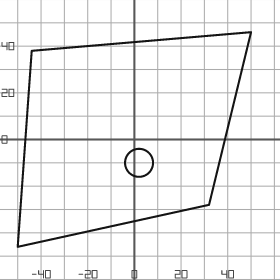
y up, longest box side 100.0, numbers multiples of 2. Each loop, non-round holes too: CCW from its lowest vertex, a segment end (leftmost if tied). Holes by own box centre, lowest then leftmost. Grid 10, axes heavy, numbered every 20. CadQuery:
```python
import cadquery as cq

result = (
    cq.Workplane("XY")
    .moveTo(-50.0, -46.0)
    .lineTo(32.0, -28.0)
    .lineTo(50.0, 46.0)
    .lineTo(-44.0, 38.0)
    .close()
    .moveTo(2.0, -10.0)
    .circle(6.0)
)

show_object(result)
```